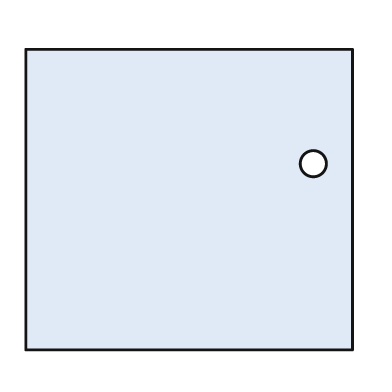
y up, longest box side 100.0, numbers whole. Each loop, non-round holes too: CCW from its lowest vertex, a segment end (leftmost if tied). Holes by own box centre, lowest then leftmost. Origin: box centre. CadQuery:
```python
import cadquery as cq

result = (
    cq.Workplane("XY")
    .moveTo(-50.0, -46.0)
    .lineTo(50.0, -46.0)
    .lineTo(50.0, 46.0)
    .lineTo(-50.0, 46.0)
    .close()
    .moveTo(38.0, 11.0)
    .circle(4.0)
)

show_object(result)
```